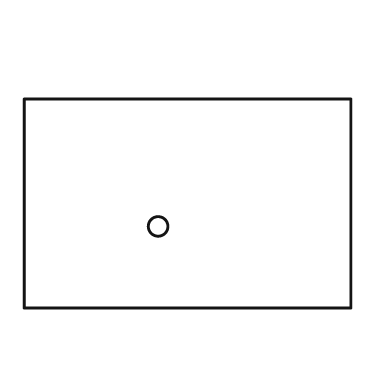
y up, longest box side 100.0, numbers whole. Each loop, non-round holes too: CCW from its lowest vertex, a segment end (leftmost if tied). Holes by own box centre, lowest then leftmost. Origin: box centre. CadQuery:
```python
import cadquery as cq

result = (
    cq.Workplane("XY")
    .moveTo(-50.0, -32.0)
    .lineTo(50.0, -32.0)
    .lineTo(50.0, 32.0)
    .lineTo(-50.0, 32.0)
    .close()
    .moveTo(-9.0, -7.0)
    .circle(3.0)
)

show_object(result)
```